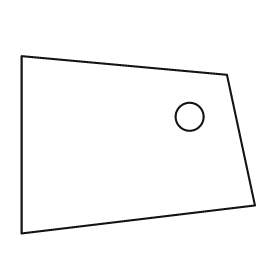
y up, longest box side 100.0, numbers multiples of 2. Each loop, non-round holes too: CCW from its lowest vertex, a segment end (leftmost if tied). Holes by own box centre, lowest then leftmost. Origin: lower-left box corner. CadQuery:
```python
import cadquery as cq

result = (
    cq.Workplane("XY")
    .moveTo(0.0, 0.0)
    .lineTo(100.0, 12.0)
    .lineTo(88.0, 68.0)
    .lineTo(0.0, 76.0)
    .close()
    .moveTo(72.0, 50.0)
    .circle(6.0)
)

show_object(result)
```